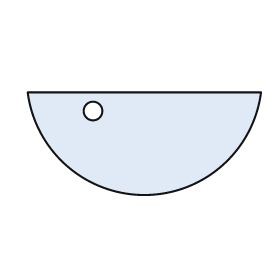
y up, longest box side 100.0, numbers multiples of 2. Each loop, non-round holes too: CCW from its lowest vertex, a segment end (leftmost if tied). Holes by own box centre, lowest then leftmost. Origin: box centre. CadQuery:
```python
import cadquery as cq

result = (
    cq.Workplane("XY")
    .moveTo(-50.0, 22.0)
    .threePointArc((0.0, -22.0), (50.0, 22.0))
    .close()
    .moveTo(-22.0, 14.0)
    .circle(4.0)
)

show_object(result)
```